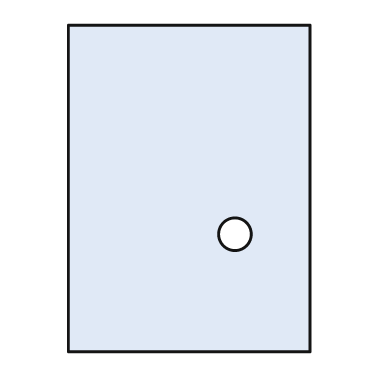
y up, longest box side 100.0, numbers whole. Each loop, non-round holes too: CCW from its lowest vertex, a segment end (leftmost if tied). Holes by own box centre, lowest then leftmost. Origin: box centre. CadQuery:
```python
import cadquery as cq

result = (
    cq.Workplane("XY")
    .moveTo(-37.0, -50.0)
    .lineTo(37.0, -50.0)
    .lineTo(37.0, 50.0)
    .lineTo(-37.0, 50.0)
    .close()
    .moveTo(14.0, -14.0)
    .circle(5.0)
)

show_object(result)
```